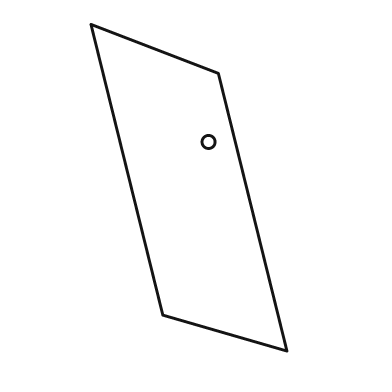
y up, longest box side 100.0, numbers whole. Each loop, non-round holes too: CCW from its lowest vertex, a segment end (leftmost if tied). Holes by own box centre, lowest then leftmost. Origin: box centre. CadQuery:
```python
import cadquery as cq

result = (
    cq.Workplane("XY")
    .moveTo(30.0, -50.0)
    .lineTo(9.0, 35.0)
    .lineTo(-30.0, 50.0)
    .lineTo(-8.0, -39.0)
    .close()
    .moveTo(6.0, 14.0)
    .circle(2.0)
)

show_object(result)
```